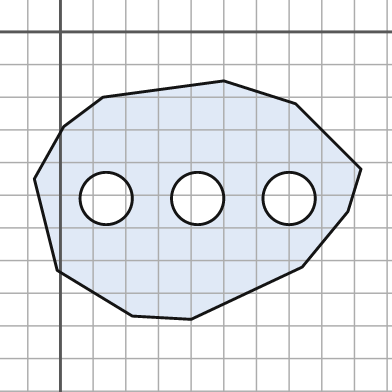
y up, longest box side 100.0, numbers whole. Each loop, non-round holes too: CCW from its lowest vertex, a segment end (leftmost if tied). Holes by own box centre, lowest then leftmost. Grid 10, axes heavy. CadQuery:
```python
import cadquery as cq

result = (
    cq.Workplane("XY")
    .moveTo(40.0, -88.0)
    .lineTo(74.0, -72.0)
    .lineTo(88.0, -55.0)
    .lineTo(92.0, -42.0)
    .lineTo(72.0, -22.0)
    .lineTo(50.0, -15.0)
    .lineTo(13.0, -20.0)
    .lineTo(1.0, -29.0)
    .lineTo(-8.0, -45.0)
    .lineTo(-1.0, -73.0)
    .lineTo(22.0, -87.0)
    .close()
    .moveTo(14.0, -51.0)
    .circle(8.0)
    .moveTo(42.0, -51.0)
    .circle(8.0)
    .moveTo(70.0, -51.0)
    .circle(8.0)
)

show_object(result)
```